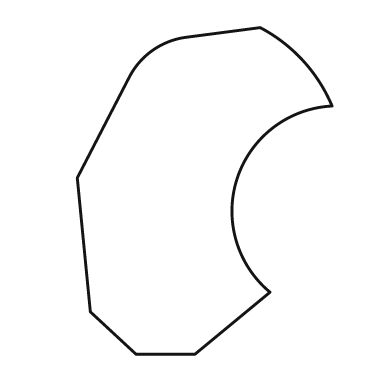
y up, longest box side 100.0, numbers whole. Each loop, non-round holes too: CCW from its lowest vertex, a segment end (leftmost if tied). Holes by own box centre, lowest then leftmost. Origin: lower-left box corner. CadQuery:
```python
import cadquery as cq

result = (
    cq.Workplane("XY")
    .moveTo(18.0, 0.0)
    .lineTo(36.0, 0.0)
    .lineTo(59.0, 19.0)
    .threePointArc((49.0, 54.0), (78.0, 76.0))
    .threePointArc((69.0, 90.0), (56.0, 100.0))
    .lineTo(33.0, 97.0)
    .threePointArc((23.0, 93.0), (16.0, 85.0))
    .lineTo(0.0, 54.0)
    .lineTo(4.0, 13.0)
    .close()
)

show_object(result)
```